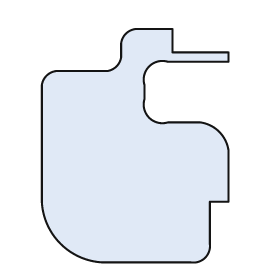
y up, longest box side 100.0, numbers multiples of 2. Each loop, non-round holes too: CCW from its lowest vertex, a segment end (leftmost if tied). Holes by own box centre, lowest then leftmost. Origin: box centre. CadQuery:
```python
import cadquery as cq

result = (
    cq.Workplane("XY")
    .moveTo(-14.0, -50.0)
    .lineTo(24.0, -50.0)
    .threePointArc((30.0, -48.0), (32.0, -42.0))
    .lineTo(32.0, -24.0)
    .lineTo(40.0, -24.0)
    .lineTo(40.0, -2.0)
    .threePointArc((36.0, 6.0), (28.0, 10.0))
    .lineTo(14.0, 10.0)
    .threePointArc((6.0, 12.0), (4.0, 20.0))
    .lineTo(4.0, 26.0)
    .threePointArc((6.0, 34.0), (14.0, 36.0))
    .lineTo(40.0, 36.0)
    .lineTo(40.0, 40.0)
    .lineTo(16.0, 40.0)
    .lineTo(16.0, 50.0)
    .lineTo(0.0, 50.0)
    .threePointArc((-4.0, 48.0), (-6.0, 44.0))
    .lineTo(-6.0, 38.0)
    .threePointArc((-8.0, 34.0), (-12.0, 32.0))
    .lineTo(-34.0, 32.0)
    .threePointArc((-38.0, 30.0), (-40.0, 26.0))
    .lineTo(-40.0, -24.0)
    .threePointArc((-32.0, -42.0), (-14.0, -50.0))
    .close()
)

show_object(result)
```